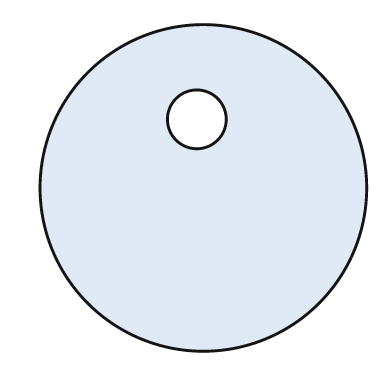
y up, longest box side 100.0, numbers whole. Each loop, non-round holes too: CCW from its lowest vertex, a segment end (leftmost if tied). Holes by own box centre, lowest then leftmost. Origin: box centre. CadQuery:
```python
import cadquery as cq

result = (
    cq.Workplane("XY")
    .moveTo(0.0, 0.0)
    .circle(50.0)
    .moveTo(-2.0, 21.0)
    .circle(9.0)
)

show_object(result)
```